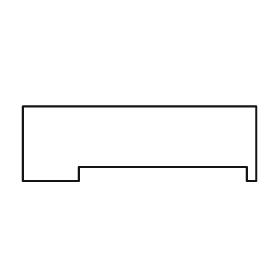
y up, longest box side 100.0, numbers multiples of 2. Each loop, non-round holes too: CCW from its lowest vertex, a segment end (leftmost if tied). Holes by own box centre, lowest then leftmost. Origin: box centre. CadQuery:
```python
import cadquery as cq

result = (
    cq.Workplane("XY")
    .moveTo(-50.0, -16.0)
    .lineTo(-26.0, -16.0)
    .lineTo(-26.0, -10.0)
    .lineTo(46.0, -10.0)
    .lineTo(46.0, -16.0)
    .lineTo(50.0, -16.0)
    .lineTo(50.0, 16.0)
    .lineTo(-50.0, 16.0)
    .close()
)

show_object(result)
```